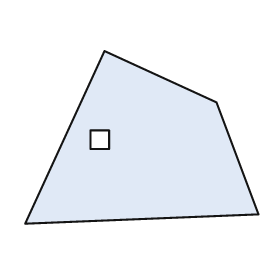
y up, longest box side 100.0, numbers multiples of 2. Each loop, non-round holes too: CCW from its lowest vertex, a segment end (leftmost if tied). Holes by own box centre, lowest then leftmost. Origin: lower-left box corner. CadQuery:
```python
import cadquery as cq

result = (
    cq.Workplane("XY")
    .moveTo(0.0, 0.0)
    .lineTo(100.0, 4.0)
    .lineTo(82.0, 52.0)
    .lineTo(34.0, 74.0)
    .close()
    .moveTo(28.0, 32.0)
    .lineTo(36.0, 32.0)
    .lineTo(36.0, 40.0)
    .lineTo(28.0, 40.0)
    .close()
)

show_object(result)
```